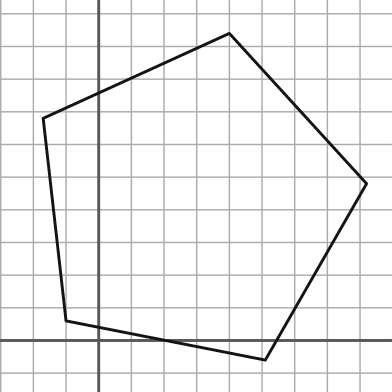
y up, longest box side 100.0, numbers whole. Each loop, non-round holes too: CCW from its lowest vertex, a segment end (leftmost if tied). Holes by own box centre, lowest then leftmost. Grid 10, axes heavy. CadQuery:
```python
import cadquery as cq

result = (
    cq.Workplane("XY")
    .moveTo(51.0, -6.0)
    .lineTo(82.0, 48.0)
    .lineTo(40.0, 94.0)
    .lineTo(-17.0, 68.0)
    .lineTo(-10.0, 6.0)
    .close()
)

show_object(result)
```